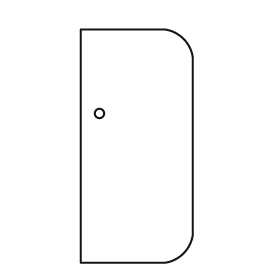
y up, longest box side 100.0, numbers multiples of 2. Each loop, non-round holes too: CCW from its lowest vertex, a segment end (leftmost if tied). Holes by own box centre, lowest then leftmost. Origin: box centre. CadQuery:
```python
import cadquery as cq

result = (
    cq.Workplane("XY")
    .moveTo(-24.0, -50.0)
    .lineTo(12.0, -50.0)
    .threePointArc((20.0, -46.0), (24.0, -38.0))
    .lineTo(24.0, 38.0)
    .threePointArc((20.0, 46.0), (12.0, 50.0))
    .lineTo(-24.0, 50.0)
    .close()
    .moveTo(-16.0, 14.0)
    .circle(2.0)
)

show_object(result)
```